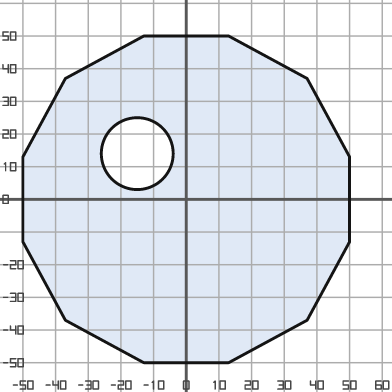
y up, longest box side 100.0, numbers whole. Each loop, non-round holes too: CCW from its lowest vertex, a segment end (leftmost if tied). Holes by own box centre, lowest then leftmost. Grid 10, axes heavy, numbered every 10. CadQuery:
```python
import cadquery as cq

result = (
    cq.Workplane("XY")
    .moveTo(-13.0, -50.0)
    .lineTo(13.0, -50.0)
    .lineTo(37.0, -37.0)
    .lineTo(50.0, -13.0)
    .lineTo(50.0, 13.0)
    .lineTo(37.0, 37.0)
    .lineTo(13.0, 50.0)
    .lineTo(-13.0, 50.0)
    .lineTo(-37.0, 37.0)
    .lineTo(-50.0, 13.0)
    .lineTo(-50.0, -13.0)
    .lineTo(-37.0, -37.0)
    .close()
    .moveTo(-15.0, 14.0)
    .circle(11.0)
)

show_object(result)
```